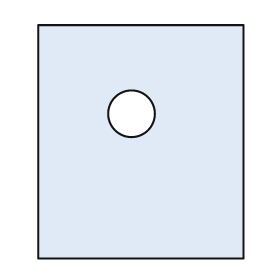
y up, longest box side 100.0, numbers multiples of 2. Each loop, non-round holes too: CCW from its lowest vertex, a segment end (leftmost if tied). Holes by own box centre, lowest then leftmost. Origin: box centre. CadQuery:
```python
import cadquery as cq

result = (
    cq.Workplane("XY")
    .moveTo(-44.0, -50.0)
    .lineTo(44.0, -50.0)
    .lineTo(44.0, 50.0)
    .lineTo(-44.0, 50.0)
    .close()
    .moveTo(-4.0, 12.0)
    .circle(10.0)
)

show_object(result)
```